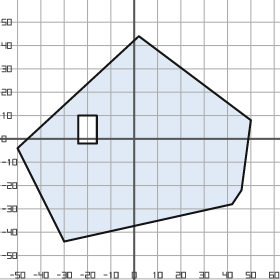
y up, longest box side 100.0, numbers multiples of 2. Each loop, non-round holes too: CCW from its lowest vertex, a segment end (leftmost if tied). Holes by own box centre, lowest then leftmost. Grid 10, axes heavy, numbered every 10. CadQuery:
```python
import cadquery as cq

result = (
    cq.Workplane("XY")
    .moveTo(-30.0, -44.0)
    .lineTo(42.0, -28.0)
    .lineTo(46.0, -22.0)
    .lineTo(50.0, 8.0)
    .lineTo(2.0, 44.0)
    .lineTo(-50.0, -4.0)
    .close()
    .moveTo(-24.0, -2.0)
    .lineTo(-16.0, -2.0)
    .lineTo(-16.0, 10.0)
    .lineTo(-24.0, 10.0)
    .close()
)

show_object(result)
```